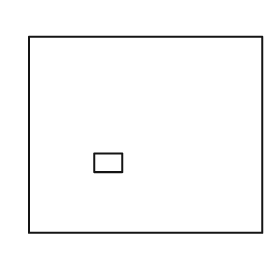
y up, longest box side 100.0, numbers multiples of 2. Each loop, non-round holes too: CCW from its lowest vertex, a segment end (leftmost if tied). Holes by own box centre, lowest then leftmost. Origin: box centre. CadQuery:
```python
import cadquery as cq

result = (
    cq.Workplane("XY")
    .moveTo(-50.0, -42.0)
    .lineTo(50.0, -42.0)
    .lineTo(50.0, 42.0)
    .lineTo(-50.0, 42.0)
    .close()
    .moveTo(-22.0, -16.0)
    .lineTo(-10.0, -16.0)
    .lineTo(-10.0, -8.0)
    .lineTo(-22.0, -8.0)
    .close()
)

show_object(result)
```